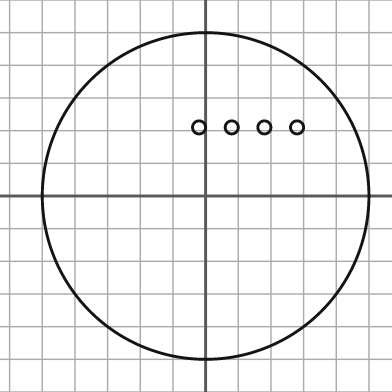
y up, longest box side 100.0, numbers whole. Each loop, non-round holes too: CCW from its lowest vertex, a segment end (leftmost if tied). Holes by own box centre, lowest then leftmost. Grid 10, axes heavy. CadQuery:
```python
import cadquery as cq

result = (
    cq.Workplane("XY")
    .moveTo(0.0, 0.0)
    .circle(50.0)
    .moveTo(-2.0, 21.0)
    .circle(2.0)
    .moveTo(8.0, 21.0)
    .circle(2.0)
    .moveTo(18.0, 21.0)
    .circle(2.0)
    .moveTo(28.0, 21.0)
    .circle(2.0)
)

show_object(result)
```